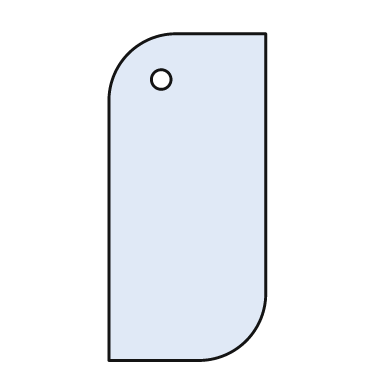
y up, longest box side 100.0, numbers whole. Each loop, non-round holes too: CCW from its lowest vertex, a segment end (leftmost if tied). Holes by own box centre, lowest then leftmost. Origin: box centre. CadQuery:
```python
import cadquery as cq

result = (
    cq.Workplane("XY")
    .moveTo(-24.0, -50.0)
    .lineTo(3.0, -50.0)
    .threePointArc((18.0, -44.0), (24.0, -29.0))
    .lineTo(24.0, 50.0)
    .lineTo(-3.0, 50.0)
    .threePointArc((-18.0, 44.0), (-24.0, 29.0))
    .close()
    .moveTo(-8.0, 36.0)
    .circle(3.0)
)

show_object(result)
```